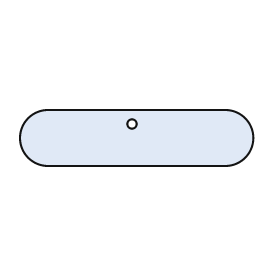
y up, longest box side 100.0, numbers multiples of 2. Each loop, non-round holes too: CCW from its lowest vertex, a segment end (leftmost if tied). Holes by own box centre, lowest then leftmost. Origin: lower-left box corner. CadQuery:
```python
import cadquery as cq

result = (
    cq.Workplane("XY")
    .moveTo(12.0, 0.0)
    .lineTo(88.0, 0.0)
    .threePointArc((100.0, 12.0), (88.0, 24.0))
    .lineTo(12.0, 24.0)
    .threePointArc((0.0, 12.0), (12.0, 0.0))
    .close()
    .moveTo(48.0, 18.0)
    .circle(2.0)
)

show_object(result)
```